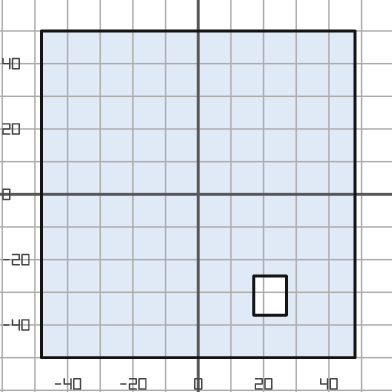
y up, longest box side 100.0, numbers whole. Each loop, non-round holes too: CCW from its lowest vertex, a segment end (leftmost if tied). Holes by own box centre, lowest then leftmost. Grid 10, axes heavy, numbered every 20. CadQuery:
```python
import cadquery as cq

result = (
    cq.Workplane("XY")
    .moveTo(-48.0, -50.0)
    .lineTo(48.0, -50.0)
    .lineTo(48.0, 50.0)
    .lineTo(-48.0, 50.0)
    .close()
    .moveTo(17.0, -37.0)
    .lineTo(27.0, -37.0)
    .lineTo(27.0, -25.0)
    .lineTo(17.0, -25.0)
    .close()
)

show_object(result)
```